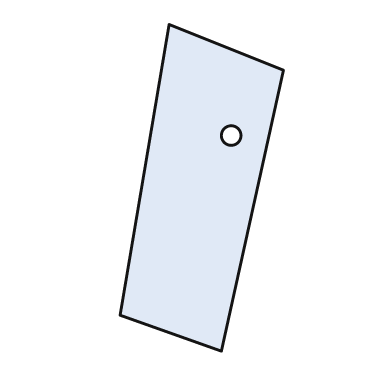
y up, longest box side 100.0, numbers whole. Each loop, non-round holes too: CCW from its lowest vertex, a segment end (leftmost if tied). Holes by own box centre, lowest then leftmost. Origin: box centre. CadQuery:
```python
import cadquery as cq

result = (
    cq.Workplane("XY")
    .moveTo(6.0, -50.0)
    .lineTo(25.0, 36.0)
    .lineTo(-10.0, 50.0)
    .lineTo(-25.0, -39.0)
    .close()
    .moveTo(9.0, 16.0)
    .circle(3.0)
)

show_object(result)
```